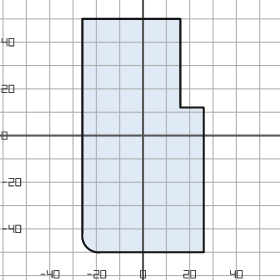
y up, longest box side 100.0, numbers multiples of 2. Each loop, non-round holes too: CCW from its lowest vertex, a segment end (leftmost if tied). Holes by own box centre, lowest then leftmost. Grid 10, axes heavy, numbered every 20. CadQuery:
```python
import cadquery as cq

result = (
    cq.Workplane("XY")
    .moveTo(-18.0, -50.0)
    .lineTo(26.0, -50.0)
    .lineTo(26.0, 12.0)
    .lineTo(16.0, 12.0)
    .lineTo(16.0, 50.0)
    .lineTo(-26.0, 50.0)
    .lineTo(-26.0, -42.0)
    .threePointArc((-24.0, -48.0), (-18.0, -50.0))
    .close()
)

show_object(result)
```